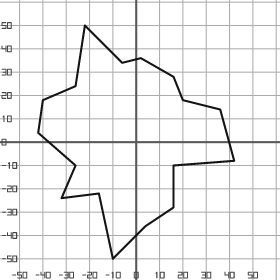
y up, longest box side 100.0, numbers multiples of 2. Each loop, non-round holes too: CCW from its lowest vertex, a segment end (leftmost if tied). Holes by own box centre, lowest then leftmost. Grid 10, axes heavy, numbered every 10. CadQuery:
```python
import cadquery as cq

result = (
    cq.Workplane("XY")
    .moveTo(-10.0, -50.0)
    .lineTo(4.0, -36.0)
    .lineTo(16.0, -28.0)
    .lineTo(16.0, -10.0)
    .lineTo(42.0, -8.0)
    .lineTo(36.0, 14.0)
    .lineTo(20.0, 18.0)
    .lineTo(16.0, 28.0)
    .lineTo(2.0, 36.0)
    .lineTo(-6.0, 34.0)
    .lineTo(-22.0, 50.0)
    .lineTo(-26.0, 24.0)
    .lineTo(-40.0, 18.0)
    .lineTo(-42.0, 4.0)
    .lineTo(-26.0, -10.0)
    .lineTo(-32.0, -24.0)
    .lineTo(-16.0, -22.0)
    .close()
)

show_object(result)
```